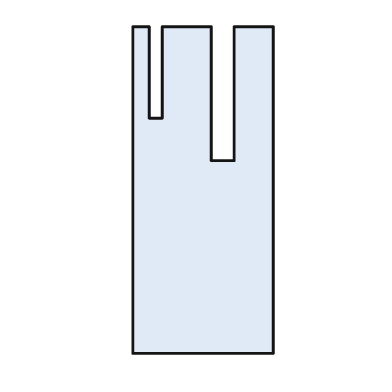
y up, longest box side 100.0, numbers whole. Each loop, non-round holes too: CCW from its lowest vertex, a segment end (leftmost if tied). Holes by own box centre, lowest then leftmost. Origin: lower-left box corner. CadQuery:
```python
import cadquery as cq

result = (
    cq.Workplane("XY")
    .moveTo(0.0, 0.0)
    .lineTo(43.0, 0.0)
    .lineTo(43.0, 100.0)
    .lineTo(31.0, 100.0)
    .lineTo(31.0, 59.0)
    .lineTo(24.0, 59.0)
    .lineTo(24.0, 100.0)
    .lineTo(9.0, 100.0)
    .lineTo(9.0, 72.0)
    .lineTo(5.0, 72.0)
    .lineTo(5.0, 100.0)
    .lineTo(0.0, 100.0)
    .close()
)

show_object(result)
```